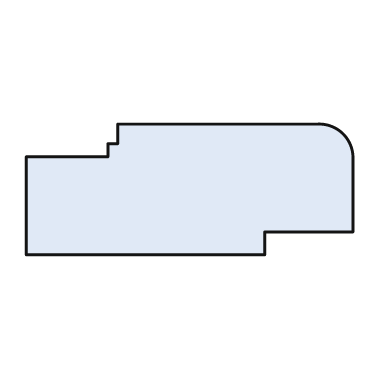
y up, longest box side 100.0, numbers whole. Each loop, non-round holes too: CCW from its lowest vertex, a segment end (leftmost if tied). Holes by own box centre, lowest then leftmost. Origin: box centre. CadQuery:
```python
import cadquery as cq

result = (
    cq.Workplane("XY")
    .moveTo(-50.0, -20.0)
    .lineTo(23.0, -20.0)
    .lineTo(23.0, -13.0)
    .lineTo(50.0, -13.0)
    .lineTo(50.0, 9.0)
    .threePointArc((47.0, 17.0), (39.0, 20.0))
    .lineTo(-22.0, 20.0)
    .lineTo(-22.0, 14.0)
    .lineTo(-25.0, 14.0)
    .lineTo(-25.0, 10.0)
    .lineTo(-50.0, 10.0)
    .close()
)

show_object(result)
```